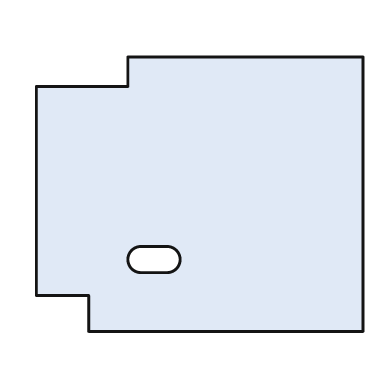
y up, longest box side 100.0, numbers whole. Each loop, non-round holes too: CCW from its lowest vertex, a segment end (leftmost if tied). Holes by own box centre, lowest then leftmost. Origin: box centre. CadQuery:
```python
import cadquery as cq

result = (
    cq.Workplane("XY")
    .moveTo(-34.0, -42.0)
    .lineTo(50.0, -42.0)
    .lineTo(50.0, 42.0)
    .lineTo(-22.0, 42.0)
    .lineTo(-22.0, 33.0)
    .lineTo(-50.0, 33.0)
    .lineTo(-50.0, -31.0)
    .lineTo(-34.0, -31.0)
    .close()
    .moveTo(-18.0, -24.0)
    .lineTo(-10.0, -24.0)
    .threePointArc((-6.0, -20.0), (-10.0, -16.0))
    .lineTo(-18.0, -16.0)
    .threePointArc((-22.0, -20.0), (-18.0, -24.0))
    .close()
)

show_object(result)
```